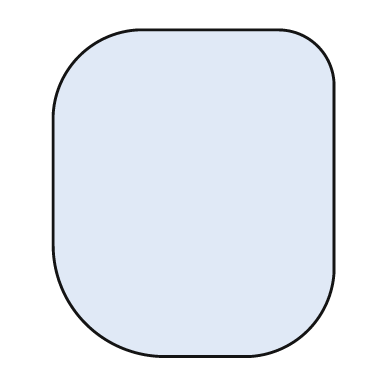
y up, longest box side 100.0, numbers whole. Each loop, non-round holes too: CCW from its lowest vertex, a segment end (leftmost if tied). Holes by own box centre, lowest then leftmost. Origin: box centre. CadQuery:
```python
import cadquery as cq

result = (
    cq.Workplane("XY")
    .moveTo(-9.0, -50.0)
    .lineTo(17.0, -50.0)
    .threePointArc((35.0, -42.0), (43.0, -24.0))
    .lineTo(43.0, 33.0)
    .threePointArc((38.0, 45.0), (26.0, 50.0))
    .lineTo(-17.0, 50.0)
    .threePointArc((-35.0, 42.0), (-43.0, 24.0))
    .lineTo(-43.0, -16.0)
    .threePointArc((-33.0, -40.0), (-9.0, -50.0))
    .close()
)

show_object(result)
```